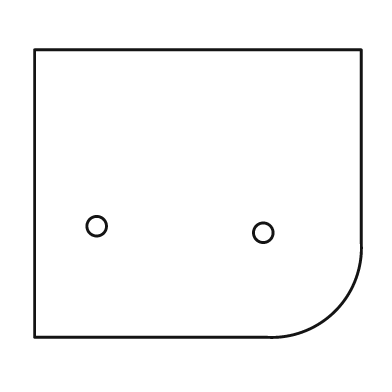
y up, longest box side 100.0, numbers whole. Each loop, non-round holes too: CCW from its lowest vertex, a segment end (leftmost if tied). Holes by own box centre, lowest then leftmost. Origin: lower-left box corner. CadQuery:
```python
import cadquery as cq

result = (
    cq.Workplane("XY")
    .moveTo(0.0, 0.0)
    .lineTo(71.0, 0.0)
    .threePointArc((92.0, 8.0), (100.0, 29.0))
    .lineTo(100.0, 88.0)
    .lineTo(0.0, 88.0)
    .close()
    .moveTo(70.0, 32.0)
    .circle(3.0)
    .moveTo(19.0, 34.0)
    .circle(3.0)
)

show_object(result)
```